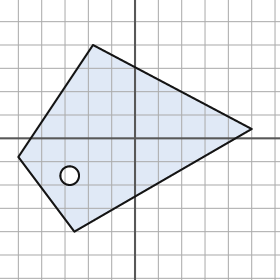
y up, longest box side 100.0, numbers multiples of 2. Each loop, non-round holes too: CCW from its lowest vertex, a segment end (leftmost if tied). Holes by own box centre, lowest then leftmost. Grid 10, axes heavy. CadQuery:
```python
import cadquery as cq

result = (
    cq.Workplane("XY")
    .moveTo(-26.0, -40.0)
    .lineTo(50.0, 4.0)
    .lineTo(-18.0, 40.0)
    .lineTo(-50.0, -8.0)
    .close()
    .moveTo(-28.0, -16.0)
    .circle(4.0)
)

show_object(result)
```